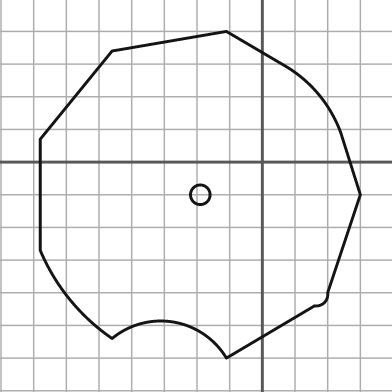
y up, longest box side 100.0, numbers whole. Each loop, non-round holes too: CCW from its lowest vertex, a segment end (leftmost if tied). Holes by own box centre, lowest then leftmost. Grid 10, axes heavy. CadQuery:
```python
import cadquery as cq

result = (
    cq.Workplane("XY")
    .moveTo(-11.0, -60.0)
    .lineTo(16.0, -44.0)
    .threePointArc((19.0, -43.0), (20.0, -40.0))
    .lineTo(30.0, -10.0)
    .lineTo(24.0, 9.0)
    .threePointArc((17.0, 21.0), (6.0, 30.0))
    .lineTo(-11.0, 40.0)
    .lineTo(-46.0, 34.0)
    .lineTo(-68.0, 7.0)
    .lineTo(-68.0, -27.0)
    .threePointArc((-59.0, -42.0), (-46.0, -54.0))
    .threePointArc((-27.0, -49.0), (-11.0, -60.0))
    .close()
    .moveTo(-19.0, -10.0)
    .circle(3.0)
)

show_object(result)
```